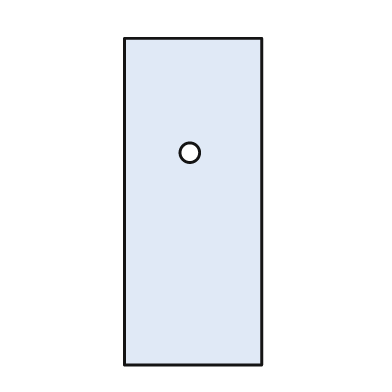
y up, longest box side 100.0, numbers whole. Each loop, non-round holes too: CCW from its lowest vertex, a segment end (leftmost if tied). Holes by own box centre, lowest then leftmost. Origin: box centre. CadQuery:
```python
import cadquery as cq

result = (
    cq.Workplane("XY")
    .moveTo(-21.0, -50.0)
    .lineTo(21.0, -50.0)
    .lineTo(21.0, 50.0)
    .lineTo(-21.0, 50.0)
    .close()
    .moveTo(-1.0, 15.0)
    .circle(3.0)
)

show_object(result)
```